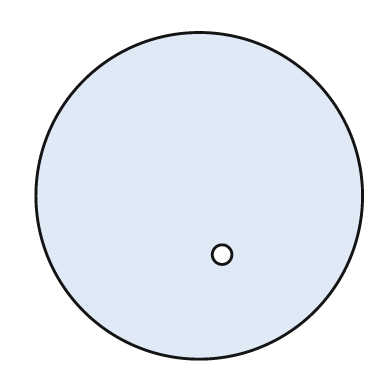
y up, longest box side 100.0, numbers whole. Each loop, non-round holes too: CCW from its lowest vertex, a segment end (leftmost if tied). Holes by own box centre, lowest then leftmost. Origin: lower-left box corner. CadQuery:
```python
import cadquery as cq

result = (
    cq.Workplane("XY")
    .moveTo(50.0, 50.0)
    .circle(50.0)
    .moveTo(57.0, 32.0)
    .circle(3.0)
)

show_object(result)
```